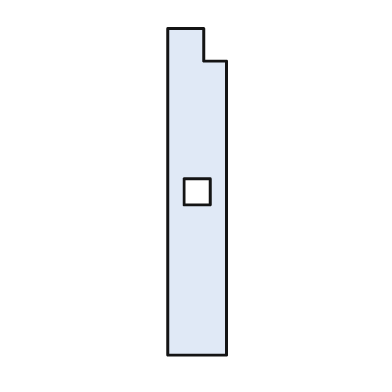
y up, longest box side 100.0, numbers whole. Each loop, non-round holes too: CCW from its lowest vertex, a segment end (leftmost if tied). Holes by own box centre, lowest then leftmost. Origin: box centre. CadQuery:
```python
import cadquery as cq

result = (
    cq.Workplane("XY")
    .moveTo(-9.0, -50.0)
    .lineTo(9.0, -50.0)
    .lineTo(9.0, 40.0)
    .lineTo(2.0, 40.0)
    .lineTo(2.0, 50.0)
    .lineTo(-9.0, 50.0)
    .close()
    .moveTo(-4.0, -4.0)
    .lineTo(4.0, -4.0)
    .lineTo(4.0, 4.0)
    .lineTo(-4.0, 4.0)
    .close()
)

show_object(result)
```